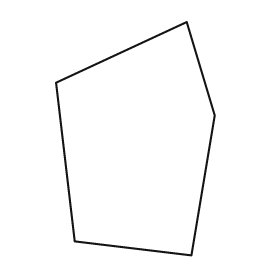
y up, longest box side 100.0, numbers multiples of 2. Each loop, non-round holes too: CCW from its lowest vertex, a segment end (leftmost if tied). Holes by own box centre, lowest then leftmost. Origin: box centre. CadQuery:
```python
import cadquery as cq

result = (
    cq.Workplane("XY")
    .moveTo(24.0, -50.0)
    .lineTo(34.0, 10.0)
    .lineTo(22.0, 50.0)
    .lineTo(-34.0, 24.0)
    .lineTo(-26.0, -44.0)
    .close()
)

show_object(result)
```